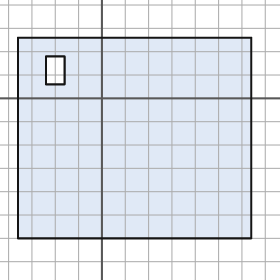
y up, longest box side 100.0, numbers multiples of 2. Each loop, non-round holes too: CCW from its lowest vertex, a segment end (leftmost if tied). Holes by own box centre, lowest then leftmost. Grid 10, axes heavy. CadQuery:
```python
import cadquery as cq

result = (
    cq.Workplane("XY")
    .moveTo(-36.0, -60.0)
    .lineTo(64.0, -60.0)
    .lineTo(64.0, 26.0)
    .lineTo(-36.0, 26.0)
    .close()
    .moveTo(-24.0, 6.0)
    .lineTo(-16.0, 6.0)
    .lineTo(-16.0, 18.0)
    .lineTo(-24.0, 18.0)
    .close()
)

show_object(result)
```